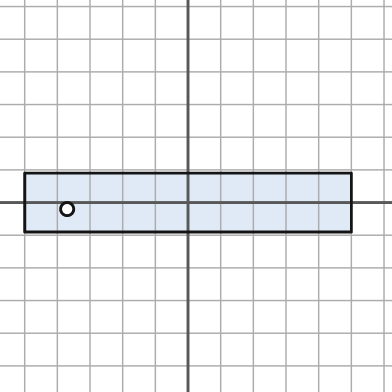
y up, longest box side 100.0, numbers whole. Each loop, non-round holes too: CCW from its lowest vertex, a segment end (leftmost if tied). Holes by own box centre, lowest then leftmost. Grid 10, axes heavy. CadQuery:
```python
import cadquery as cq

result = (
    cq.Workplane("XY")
    .moveTo(-50.0, -9.0)
    .lineTo(50.0, -9.0)
    .lineTo(50.0, 9.0)
    .lineTo(-50.0, 9.0)
    .close()
    .moveTo(-37.0, -2.0)
    .circle(2.0)
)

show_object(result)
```